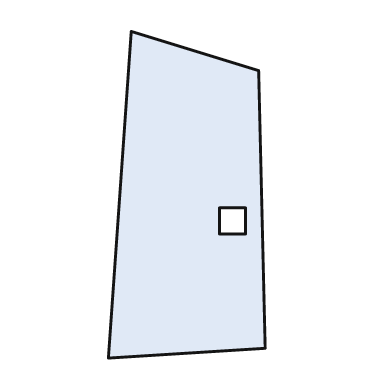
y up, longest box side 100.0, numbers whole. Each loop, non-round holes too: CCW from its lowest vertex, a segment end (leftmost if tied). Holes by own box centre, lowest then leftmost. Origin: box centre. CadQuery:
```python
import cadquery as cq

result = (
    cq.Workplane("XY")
    .moveTo(-24.0, -50.0)
    .lineTo(24.0, -47.0)
    .lineTo(22.0, 38.0)
    .lineTo(-17.0, 50.0)
    .close()
    .moveTo(10.0, -12.0)
    .lineTo(18.0, -12.0)
    .lineTo(18.0, -4.0)
    .lineTo(10.0, -4.0)
    .close()
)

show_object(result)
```